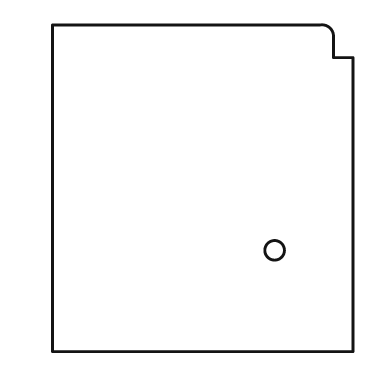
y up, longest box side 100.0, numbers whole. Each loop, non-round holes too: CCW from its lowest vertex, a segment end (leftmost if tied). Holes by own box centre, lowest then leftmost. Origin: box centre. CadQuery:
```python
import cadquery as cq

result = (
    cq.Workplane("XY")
    .moveTo(-46.0, -50.0)
    .lineTo(46.0, -50.0)
    .lineTo(46.0, 40.0)
    .lineTo(40.0, 40.0)
    .lineTo(40.0, 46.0)
    .threePointArc((39.0, 49.0), (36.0, 50.0))
    .lineTo(-46.0, 50.0)
    .close()
    .moveTo(22.0, -19.0)
    .circle(3.0)
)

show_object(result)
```